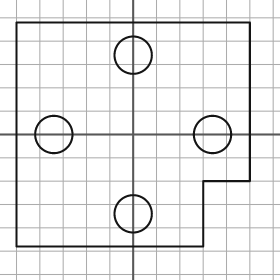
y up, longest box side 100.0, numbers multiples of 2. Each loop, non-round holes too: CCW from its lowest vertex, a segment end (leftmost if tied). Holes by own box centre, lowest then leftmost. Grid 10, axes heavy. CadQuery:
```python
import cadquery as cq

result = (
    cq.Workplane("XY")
    .moveTo(-50.0, -48.0)
    .lineTo(30.0, -48.0)
    .lineTo(30.0, -20.0)
    .lineTo(50.0, -20.0)
    .lineTo(50.0, 48.0)
    .lineTo(-50.0, 48.0)
    .close()
    .moveTo(0.0, -34.0)
    .circle(8.0)
    .moveTo(-34.0, 0.0)
    .circle(8.0)
    .moveTo(34.0, 0.0)
    .circle(8.0)
    .moveTo(0.0, 34.0)
    .circle(8.0)
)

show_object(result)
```